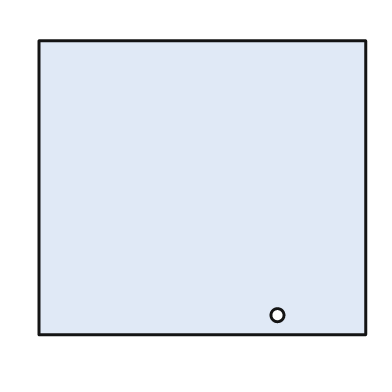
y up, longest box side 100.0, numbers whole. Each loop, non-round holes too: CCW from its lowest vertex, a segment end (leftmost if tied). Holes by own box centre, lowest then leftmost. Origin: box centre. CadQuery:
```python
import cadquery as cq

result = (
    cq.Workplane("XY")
    .moveTo(-50.0, -45.0)
    .lineTo(50.0, -45.0)
    .lineTo(50.0, 45.0)
    .lineTo(-50.0, 45.0)
    .close()
    .moveTo(23.0, -39.0)
    .circle(2.0)
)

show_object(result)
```